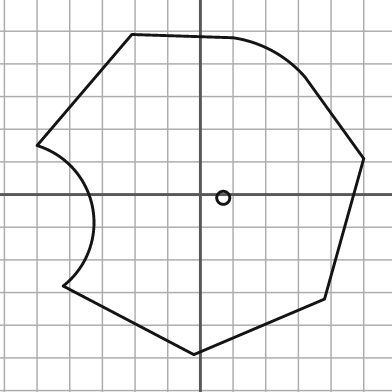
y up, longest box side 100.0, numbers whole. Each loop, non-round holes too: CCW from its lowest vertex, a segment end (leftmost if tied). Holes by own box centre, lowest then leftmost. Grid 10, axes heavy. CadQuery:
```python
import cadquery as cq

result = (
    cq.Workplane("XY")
    .moveTo(-2.0, -49.0)
    .lineTo(38.0, -32.0)
    .lineTo(50.0, 11.0)
    .lineTo(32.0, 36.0)
    .threePointArc((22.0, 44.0), (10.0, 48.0))
    .lineTo(-21.0, 49.0)
    .lineTo(-50.0, 15.0)
    .threePointArc((-33.0, -4.0), (-42.0, -28.0))
    .close()
    .moveTo(7.0, -1.0)
    .circle(2.0)
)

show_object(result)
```